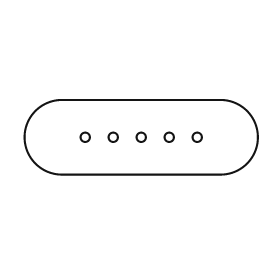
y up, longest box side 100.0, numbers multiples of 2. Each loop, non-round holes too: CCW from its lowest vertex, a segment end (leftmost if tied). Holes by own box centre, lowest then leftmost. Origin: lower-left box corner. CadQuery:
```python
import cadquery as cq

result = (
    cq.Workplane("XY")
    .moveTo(16.0, 0.0)
    .lineTo(84.0, 0.0)
    .threePointArc((100.0, 16.0), (84.0, 32.0))
    .lineTo(16.0, 32.0)
    .threePointArc((0.0, 16.0), (16.0, 0.0))
    .close()
    .moveTo(26.0, 16.0)
    .circle(2.0)
    .moveTo(38.0, 16.0)
    .circle(2.0)
    .moveTo(50.0, 16.0)
    .circle(2.0)
    .moveTo(62.0, 16.0)
    .circle(2.0)
    .moveTo(74.0, 16.0)
    .circle(2.0)
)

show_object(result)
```